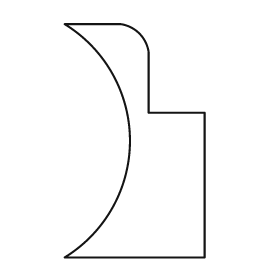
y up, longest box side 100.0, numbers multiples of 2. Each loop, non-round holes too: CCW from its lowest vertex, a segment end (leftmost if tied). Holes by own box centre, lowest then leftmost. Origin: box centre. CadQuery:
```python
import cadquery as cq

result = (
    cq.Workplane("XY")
    .moveTo(-30.0, -50.0)
    .lineTo(30.0, -50.0)
    .lineTo(30.0, 12.0)
    .lineTo(6.0, 12.0)
    .lineTo(6.0, 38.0)
    .threePointArc((2.0, 46.0), (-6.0, 50.0))
    .lineTo(-30.0, 50.0)
    .threePointArc((-2.0, 0.0), (-30.0, -50.0))
    .close()
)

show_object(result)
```